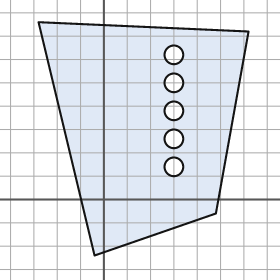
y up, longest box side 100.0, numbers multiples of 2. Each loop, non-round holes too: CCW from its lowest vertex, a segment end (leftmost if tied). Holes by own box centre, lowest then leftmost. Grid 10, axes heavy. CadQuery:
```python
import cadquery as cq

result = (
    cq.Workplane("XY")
    .moveTo(-4.0, -24.0)
    .lineTo(48.0, -6.0)
    .lineTo(62.0, 72.0)
    .lineTo(-28.0, 76.0)
    .close()
    .moveTo(30.0, 14.0)
    .circle(4.0)
    .moveTo(30.0, 26.0)
    .circle(4.0)
    .moveTo(30.0, 38.0)
    .circle(4.0)
    .moveTo(30.0, 50.0)
    .circle(4.0)
    .moveTo(30.0, 62.0)
    .circle(4.0)
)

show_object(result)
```